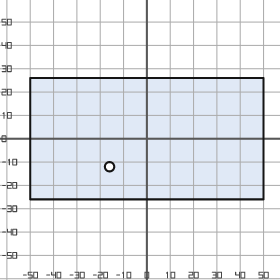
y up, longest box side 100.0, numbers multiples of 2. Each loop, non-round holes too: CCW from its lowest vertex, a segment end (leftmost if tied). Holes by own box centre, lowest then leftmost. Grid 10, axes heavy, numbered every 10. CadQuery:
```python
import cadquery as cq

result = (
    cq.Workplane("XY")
    .moveTo(-50.0, -26.0)
    .lineTo(50.0, -26.0)
    .lineTo(50.0, 26.0)
    .lineTo(-50.0, 26.0)
    .close()
    .moveTo(-16.0, -12.0)
    .circle(2.0)
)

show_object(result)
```